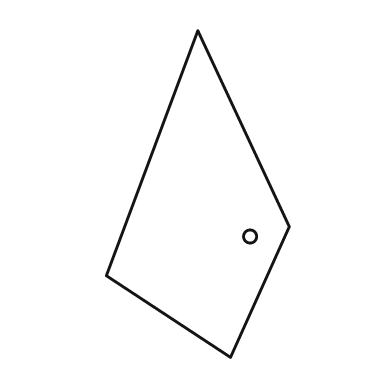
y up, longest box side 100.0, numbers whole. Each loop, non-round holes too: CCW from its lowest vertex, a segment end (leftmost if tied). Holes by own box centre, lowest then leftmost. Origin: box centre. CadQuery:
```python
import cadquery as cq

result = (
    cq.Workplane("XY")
    .moveTo(10.0, -50.0)
    .lineTo(28.0, -10.0)
    .lineTo(0.0, 50.0)
    .lineTo(-28.0, -25.0)
    .close()
    .moveTo(16.0, -13.0)
    .circle(2.0)
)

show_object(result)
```